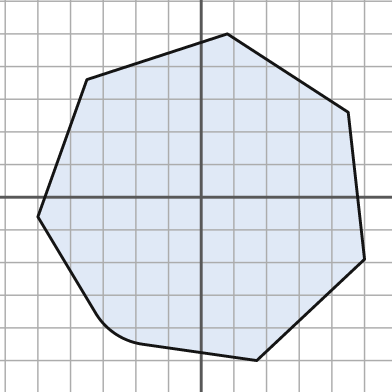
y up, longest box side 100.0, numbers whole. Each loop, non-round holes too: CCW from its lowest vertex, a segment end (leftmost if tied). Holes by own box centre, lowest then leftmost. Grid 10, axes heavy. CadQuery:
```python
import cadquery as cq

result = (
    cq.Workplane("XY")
    .moveTo(17.0, -50.0)
    .lineTo(50.0, -19.0)
    .lineTo(45.0, 26.0)
    .lineTo(8.0, 50.0)
    .lineTo(-35.0, 36.0)
    .lineTo(-50.0, -6.0)
    .lineTo(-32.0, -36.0)
    .threePointArc((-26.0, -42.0), (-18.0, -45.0))
    .close()
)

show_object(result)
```